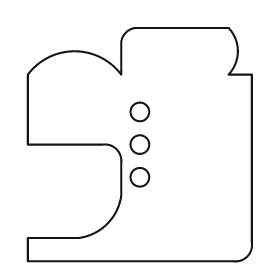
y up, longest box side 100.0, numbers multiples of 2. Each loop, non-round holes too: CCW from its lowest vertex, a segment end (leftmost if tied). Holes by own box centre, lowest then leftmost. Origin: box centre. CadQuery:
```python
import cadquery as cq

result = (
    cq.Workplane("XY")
    .moveTo(-48.0, -50.0)
    .lineTo(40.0, -50.0)
    .threePointArc((46.0, -48.0), (48.0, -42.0))
    .lineTo(48.0, 30.0)
    .lineTo(38.0, 30.0)
    .threePointArc((42.0, 40.0), (38.0, 50.0))
    .lineTo(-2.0, 50.0)
    .threePointArc((-6.0, 48.0), (-8.0, 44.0))
    .lineTo(-8.0, 30.0)
    .threePointArc((-28.0, 40.0), (-48.0, 30.0))
    .lineTo(-48.0, 0.0)
    .lineTo(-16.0, 0.0)
    .threePointArc((-10.0, -2.0), (-8.0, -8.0))
    .lineTo(-8.0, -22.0)
    .threePointArc((-14.0, -34.0), (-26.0, -40.0))
    .lineTo(-48.0, -40.0)
    .close()
    .moveTo(0.0, -14.0)
    .circle(4.0)
    .moveTo(0.0, 0.0)
    .circle(4.0)
    .moveTo(0.0, 14.0)
    .circle(4.0)
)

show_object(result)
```